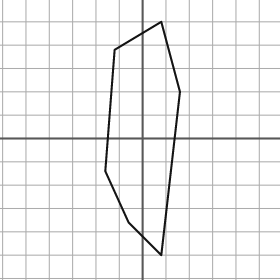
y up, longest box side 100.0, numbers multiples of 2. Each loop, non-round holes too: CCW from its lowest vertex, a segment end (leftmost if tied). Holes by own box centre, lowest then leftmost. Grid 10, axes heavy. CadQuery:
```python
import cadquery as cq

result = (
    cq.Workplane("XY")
    .moveTo(8.0, -50.0)
    .lineTo(16.0, 20.0)
    .lineTo(8.0, 50.0)
    .lineTo(-12.0, 38.0)
    .lineTo(-16.0, -14.0)
    .lineTo(-6.0, -36.0)
    .close()
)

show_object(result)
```